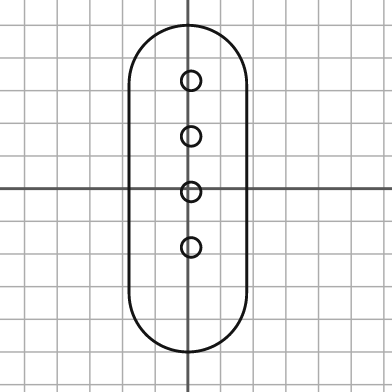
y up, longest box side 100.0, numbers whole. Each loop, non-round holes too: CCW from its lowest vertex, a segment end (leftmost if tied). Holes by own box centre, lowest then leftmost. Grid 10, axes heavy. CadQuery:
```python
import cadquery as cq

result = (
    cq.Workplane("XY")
    .moveTo(-18.0, -32.0)
    .threePointArc((0.0, -50.0), (18.0, -32.0))
    .lineTo(18.0, 32.0)
    .threePointArc((0.0, 50.0), (-18.0, 32.0))
    .close()
    .moveTo(1.0, -18.0)
    .circle(3.0)
    .moveTo(1.0, -1.0)
    .circle(3.0)
    .moveTo(1.0, 16.0)
    .circle(3.0)
    .moveTo(1.0, 33.0)
    .circle(3.0)
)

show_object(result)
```